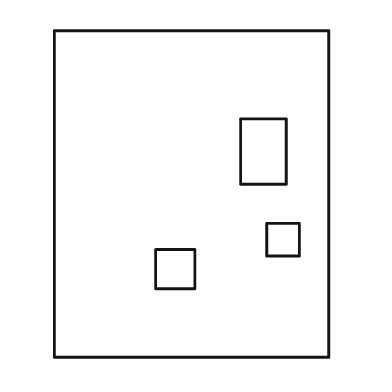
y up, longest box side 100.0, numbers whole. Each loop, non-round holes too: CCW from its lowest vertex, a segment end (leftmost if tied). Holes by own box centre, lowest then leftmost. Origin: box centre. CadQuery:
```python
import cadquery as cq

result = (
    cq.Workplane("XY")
    .moveTo(-42.0, -50.0)
    .lineTo(42.0, -50.0)
    .lineTo(42.0, 50.0)
    .lineTo(-42.0, 50.0)
    .close()
    .moveTo(-11.0, -29.0)
    .lineTo(1.0, -29.0)
    .lineTo(1.0, -17.0)
    .lineTo(-11.0, -17.0)
    .close()
    .moveTo(23.0, -19.0)
    .lineTo(33.0, -19.0)
    .lineTo(33.0, -9.0)
    .lineTo(23.0, -9.0)
    .close()
    .moveTo(15.0, 3.0)
    .lineTo(29.0, 3.0)
    .lineTo(29.0, 23.0)
    .lineTo(15.0, 23.0)
    .close()
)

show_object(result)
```